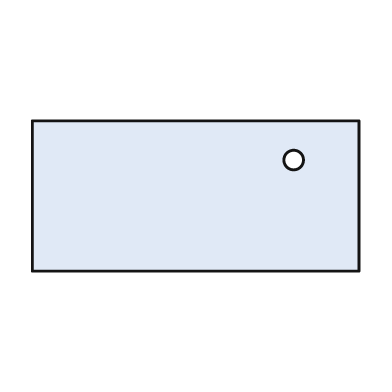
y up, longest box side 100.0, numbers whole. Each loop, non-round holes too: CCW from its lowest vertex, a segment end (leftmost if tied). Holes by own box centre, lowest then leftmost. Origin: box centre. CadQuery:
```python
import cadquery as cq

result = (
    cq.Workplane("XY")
    .moveTo(-50.0, -23.0)
    .lineTo(50.0, -23.0)
    .lineTo(50.0, 23.0)
    .lineTo(-50.0, 23.0)
    .close()
    .moveTo(30.0, 11.0)
    .circle(3.0)
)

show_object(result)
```